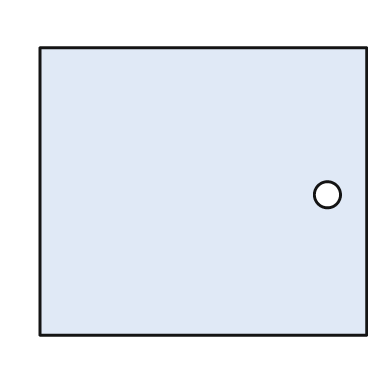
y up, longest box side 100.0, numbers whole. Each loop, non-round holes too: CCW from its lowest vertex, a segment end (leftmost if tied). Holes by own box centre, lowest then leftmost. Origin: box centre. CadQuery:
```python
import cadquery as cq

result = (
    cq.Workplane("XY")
    .moveTo(-50.0, -44.0)
    .lineTo(50.0, -44.0)
    .lineTo(50.0, 44.0)
    .lineTo(-50.0, 44.0)
    .close()
    .moveTo(38.0, -1.0)
    .circle(4.0)
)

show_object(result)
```